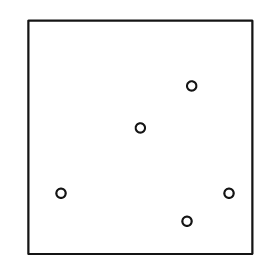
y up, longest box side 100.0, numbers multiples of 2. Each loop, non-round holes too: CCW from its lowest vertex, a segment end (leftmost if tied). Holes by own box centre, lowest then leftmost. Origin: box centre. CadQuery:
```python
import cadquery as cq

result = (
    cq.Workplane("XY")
    .moveTo(-48.0, -50.0)
    .lineTo(48.0, -50.0)
    .lineTo(48.0, 50.0)
    .lineTo(-48.0, 50.0)
    .close()
    .moveTo(20.0, -36.0)
    .circle(2.0)
    .moveTo(-34.0, -24.0)
    .circle(2.0)
    .moveTo(38.0, -24.0)
    .circle(2.0)
    .moveTo(0.0, 4.0)
    .circle(2.0)
    .moveTo(22.0, 22.0)
    .circle(2.0)
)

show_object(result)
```